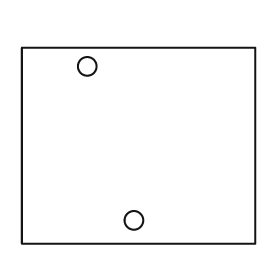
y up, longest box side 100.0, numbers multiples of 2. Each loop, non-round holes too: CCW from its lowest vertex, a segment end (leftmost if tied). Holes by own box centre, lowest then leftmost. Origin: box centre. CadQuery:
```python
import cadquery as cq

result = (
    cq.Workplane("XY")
    .moveTo(-50.0, -42.0)
    .lineTo(50.0, -42.0)
    .lineTo(50.0, 42.0)
    .lineTo(-50.0, 42.0)
    .close()
    .moveTo(-2.0, -32.0)
    .circle(4.0)
    .moveTo(-22.0, 34.0)
    .circle(4.0)
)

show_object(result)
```